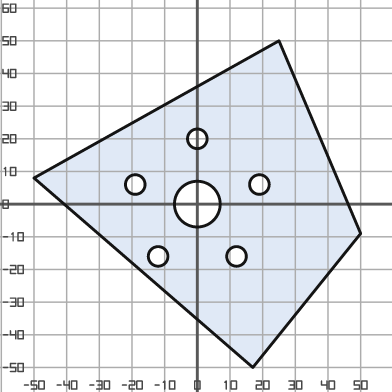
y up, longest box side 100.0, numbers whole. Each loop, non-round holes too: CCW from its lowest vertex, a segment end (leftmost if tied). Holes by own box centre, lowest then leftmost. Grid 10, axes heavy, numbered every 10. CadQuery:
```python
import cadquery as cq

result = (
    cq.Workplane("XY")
    .moveTo(17.0, -50.0)
    .lineTo(50.0, -9.0)
    .lineTo(25.0, 50.0)
    .lineTo(-50.0, 8.0)
    .close()
    .moveTo(-12.0, -16.0)
    .circle(3.0)
    .moveTo(12.0, -16.0)
    .circle(3.0)
    .moveTo(0.0, 0.0)
    .circle(7.0)
    .moveTo(-19.0, 6.0)
    .circle(3.0)
    .moveTo(19.0, 6.0)
    .circle(3.0)
    .moveTo(0.0, 20.0)
    .circle(3.0)
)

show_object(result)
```